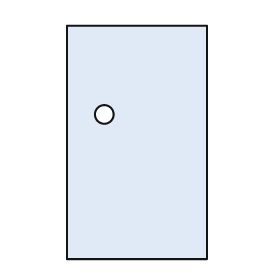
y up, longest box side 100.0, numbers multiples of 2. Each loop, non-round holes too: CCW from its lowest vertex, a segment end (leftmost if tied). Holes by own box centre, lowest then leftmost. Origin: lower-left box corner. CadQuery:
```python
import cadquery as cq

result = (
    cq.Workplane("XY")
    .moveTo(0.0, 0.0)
    .lineTo(60.0, 0.0)
    .lineTo(60.0, 100.0)
    .lineTo(0.0, 100.0)
    .close()
    .moveTo(16.0, 62.0)
    .circle(4.0)
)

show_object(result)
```